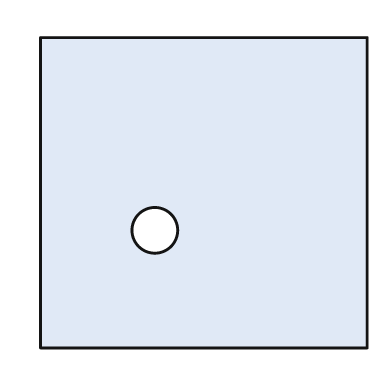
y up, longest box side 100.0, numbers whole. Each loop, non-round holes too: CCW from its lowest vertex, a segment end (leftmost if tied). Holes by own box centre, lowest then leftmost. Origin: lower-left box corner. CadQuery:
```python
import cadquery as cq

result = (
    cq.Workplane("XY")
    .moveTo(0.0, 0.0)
    .lineTo(100.0, 0.0)
    .lineTo(100.0, 95.0)
    .lineTo(0.0, 95.0)
    .close()
    .moveTo(35.0, 36.0)
    .circle(7.0)
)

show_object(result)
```